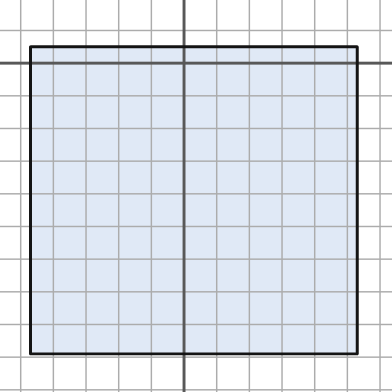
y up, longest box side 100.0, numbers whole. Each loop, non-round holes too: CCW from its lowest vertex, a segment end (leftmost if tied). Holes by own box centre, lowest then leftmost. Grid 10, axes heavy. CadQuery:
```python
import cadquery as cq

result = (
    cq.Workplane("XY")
    .moveTo(-47.0, -89.0)
    .lineTo(53.0, -89.0)
    .lineTo(53.0, 5.0)
    .lineTo(-47.0, 5.0)
    .close()
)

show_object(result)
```